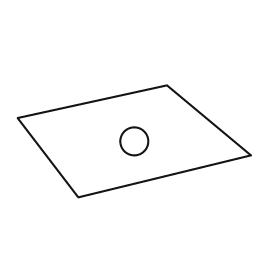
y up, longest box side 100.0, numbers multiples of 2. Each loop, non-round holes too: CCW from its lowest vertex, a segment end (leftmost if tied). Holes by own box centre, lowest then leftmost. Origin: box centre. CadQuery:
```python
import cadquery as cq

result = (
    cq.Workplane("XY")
    .moveTo(-24.0, -24.0)
    .lineTo(50.0, -6.0)
    .lineTo(14.0, 24.0)
    .lineTo(-50.0, 10.0)
    .close()
    .moveTo(0.0, 0.0)
    .circle(6.0)
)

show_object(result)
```